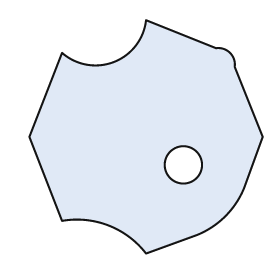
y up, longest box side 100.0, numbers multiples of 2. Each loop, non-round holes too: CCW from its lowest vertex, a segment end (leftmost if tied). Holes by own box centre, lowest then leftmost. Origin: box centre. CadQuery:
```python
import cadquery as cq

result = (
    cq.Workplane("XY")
    .moveTo(0.0, -50.0)
    .lineTo(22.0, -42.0)
    .threePointArc((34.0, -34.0), (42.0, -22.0))
    .lineTo(50.0, 0.0)
    .lineTo(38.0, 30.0)
    .threePointArc((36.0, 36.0), (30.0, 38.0))
    .lineTo(0.0, 50.0)
    .threePointArc((-14.0, 32.0), (-36.0, 36.0))
    .lineTo(-50.0, 0.0)
    .lineTo(-36.0, -36.0)
    .threePointArc((-16.0, -38.0), (0.0, -50.0))
    .close()
    .moveTo(16.0, -12.0)
    .circle(8.0)
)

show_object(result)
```